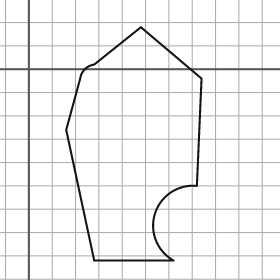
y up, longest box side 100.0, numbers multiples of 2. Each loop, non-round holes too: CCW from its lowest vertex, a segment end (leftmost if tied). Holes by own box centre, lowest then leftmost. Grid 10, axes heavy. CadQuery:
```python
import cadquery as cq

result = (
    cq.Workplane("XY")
    .moveTo(28.0, -82.0)
    .lineTo(62.0, -82.0)
    .threePointArc((54.0, -62.0), (72.0, -50.0))
    .lineTo(74.0, -4.0)
    .lineTo(48.0, 18.0)
    .lineTo(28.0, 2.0)
    .threePointArc((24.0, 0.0), (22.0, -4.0))
    .lineTo(16.0, -26.0)
    .close()
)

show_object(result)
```